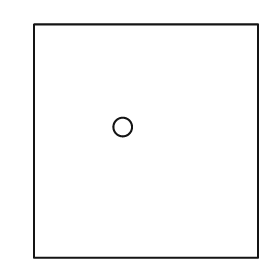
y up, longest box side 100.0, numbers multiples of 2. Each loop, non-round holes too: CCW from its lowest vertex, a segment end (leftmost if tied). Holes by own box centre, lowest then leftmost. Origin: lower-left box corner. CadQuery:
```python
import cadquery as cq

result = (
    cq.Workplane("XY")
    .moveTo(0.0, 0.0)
    .lineTo(96.0, 0.0)
    .lineTo(96.0, 100.0)
    .lineTo(0.0, 100.0)
    .close()
    .moveTo(38.0, 56.0)
    .circle(4.0)
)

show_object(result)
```